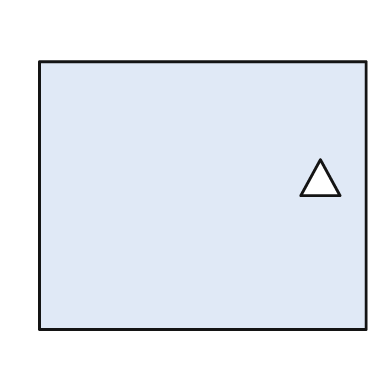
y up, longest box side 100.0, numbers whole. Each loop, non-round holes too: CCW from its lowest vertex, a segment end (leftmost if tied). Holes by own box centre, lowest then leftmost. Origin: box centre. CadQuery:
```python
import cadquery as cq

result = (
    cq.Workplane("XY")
    .moveTo(-50.0, -41.0)
    .lineTo(50.0, -41.0)
    .lineTo(50.0, 41.0)
    .lineTo(-50.0, 41.0)
    .close()
    .moveTo(30.0, 0.0)
    .lineTo(42.0, 0.0)
    .lineTo(36.0, 11.0)
    .close()
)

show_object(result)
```